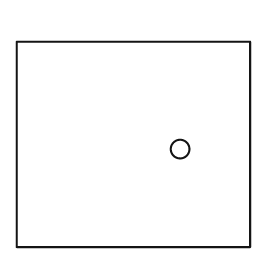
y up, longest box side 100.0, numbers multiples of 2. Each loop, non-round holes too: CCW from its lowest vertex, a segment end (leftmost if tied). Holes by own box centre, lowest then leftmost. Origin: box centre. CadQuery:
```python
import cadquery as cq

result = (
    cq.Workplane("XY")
    .moveTo(-50.0, -44.0)
    .lineTo(50.0, -44.0)
    .lineTo(50.0, 44.0)
    .lineTo(-50.0, 44.0)
    .close()
    .moveTo(20.0, -2.0)
    .circle(4.0)
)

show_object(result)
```